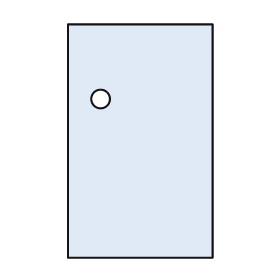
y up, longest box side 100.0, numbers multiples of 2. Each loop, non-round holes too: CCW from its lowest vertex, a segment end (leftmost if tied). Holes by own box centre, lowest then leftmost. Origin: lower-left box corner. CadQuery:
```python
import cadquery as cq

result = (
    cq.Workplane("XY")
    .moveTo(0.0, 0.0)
    .lineTo(62.0, 0.0)
    .lineTo(62.0, 100.0)
    .lineTo(0.0, 100.0)
    .close()
    .moveTo(14.0, 68.0)
    .circle(4.0)
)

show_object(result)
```